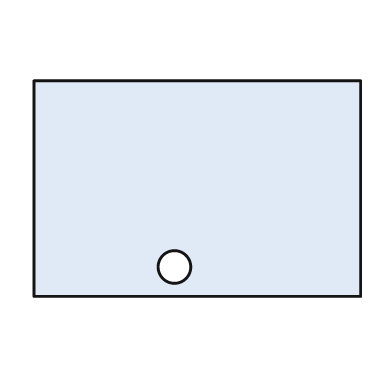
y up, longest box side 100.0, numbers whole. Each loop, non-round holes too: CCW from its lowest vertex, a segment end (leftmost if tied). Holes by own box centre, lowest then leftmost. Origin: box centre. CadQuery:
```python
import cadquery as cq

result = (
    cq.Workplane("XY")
    .moveTo(-50.0, -33.0)
    .lineTo(50.0, -33.0)
    .lineTo(50.0, 33.0)
    .lineTo(-50.0, 33.0)
    .close()
    .moveTo(-7.0, -24.0)
    .circle(5.0)
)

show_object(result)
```